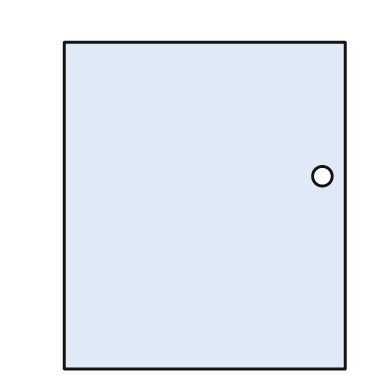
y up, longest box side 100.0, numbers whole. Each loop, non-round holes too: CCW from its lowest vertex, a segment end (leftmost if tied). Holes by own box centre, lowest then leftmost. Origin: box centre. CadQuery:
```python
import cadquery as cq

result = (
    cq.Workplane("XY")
    .moveTo(-43.0, -50.0)
    .lineTo(43.0, -50.0)
    .lineTo(43.0, 50.0)
    .lineTo(-43.0, 50.0)
    .close()
    .moveTo(36.0, 9.0)
    .circle(3.0)
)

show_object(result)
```